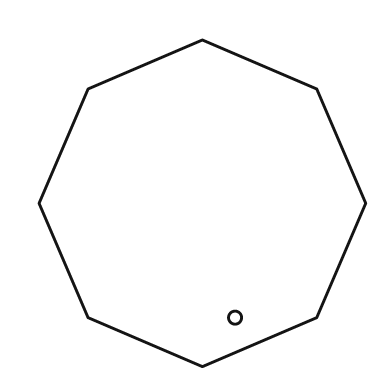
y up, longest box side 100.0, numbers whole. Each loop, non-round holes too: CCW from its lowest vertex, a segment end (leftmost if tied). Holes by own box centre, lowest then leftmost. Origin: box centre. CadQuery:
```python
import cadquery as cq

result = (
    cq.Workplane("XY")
    .moveTo(0.0, -50.0)
    .lineTo(35.0, -35.0)
    .lineTo(50.0, 0.0)
    .lineTo(35.0, 35.0)
    .lineTo(0.0, 50.0)
    .lineTo(-35.0, 35.0)
    .lineTo(-50.0, 0.0)
    .lineTo(-35.0, -35.0)
    .close()
    .moveTo(10.0, -35.0)
    .circle(2.0)
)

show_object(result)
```